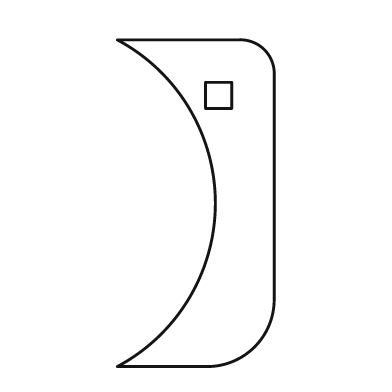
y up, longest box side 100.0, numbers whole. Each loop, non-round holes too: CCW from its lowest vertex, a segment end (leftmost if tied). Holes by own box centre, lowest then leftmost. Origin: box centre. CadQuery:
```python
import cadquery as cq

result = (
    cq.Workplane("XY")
    .moveTo(-24.0, -50.0)
    .lineTo(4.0, -50.0)
    .threePointArc((18.0, -44.0), (24.0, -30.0))
    .lineTo(24.0, 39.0)
    .threePointArc((21.0, 47.0), (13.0, 50.0))
    .lineTo(-24.0, 50.0)
    .threePointArc((6.0, 0.0), (-24.0, -50.0))
    .close()
    .moveTo(3.0, 29.0)
    .lineTo(11.0, 29.0)
    .lineTo(11.0, 37.0)
    .lineTo(3.0, 37.0)
    .close()
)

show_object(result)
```